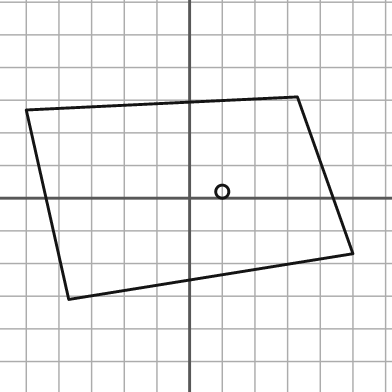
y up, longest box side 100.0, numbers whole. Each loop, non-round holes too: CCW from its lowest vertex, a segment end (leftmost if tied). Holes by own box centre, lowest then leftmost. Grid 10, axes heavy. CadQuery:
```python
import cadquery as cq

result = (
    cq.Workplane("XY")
    .moveTo(-37.0, -31.0)
    .lineTo(50.0, -17.0)
    .lineTo(33.0, 31.0)
    .lineTo(-50.0, 27.0)
    .close()
    .moveTo(10.0, 2.0)
    .circle(2.0)
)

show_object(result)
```